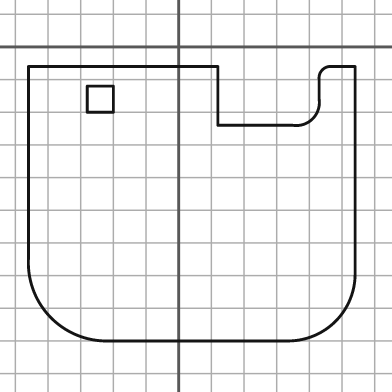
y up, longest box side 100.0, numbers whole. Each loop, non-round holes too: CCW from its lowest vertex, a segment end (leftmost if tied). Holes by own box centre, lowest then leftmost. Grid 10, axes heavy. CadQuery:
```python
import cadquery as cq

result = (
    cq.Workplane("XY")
    .moveTo(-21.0, -90.0)
    .lineTo(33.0, -90.0)
    .threePointArc((48.0, -84.0), (54.0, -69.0))
    .lineTo(54.0, -6.0)
    .lineTo(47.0, -6.0)
    .threePointArc((44.0, -7.0), (43.0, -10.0))
    .lineTo(43.0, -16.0)
    .threePointArc((41.0, -22.0), (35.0, -24.0))
    .lineTo(12.0, -24.0)
    .lineTo(12.0, -6.0)
    .lineTo(-46.0, -6.0)
    .lineTo(-46.0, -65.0)
    .threePointArc((-39.0, -83.0), (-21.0, -90.0))
    .close()
    .moveTo(-28.0, -20.0)
    .lineTo(-20.0, -20.0)
    .lineTo(-20.0, -12.0)
    .lineTo(-28.0, -12.0)
    .close()
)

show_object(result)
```